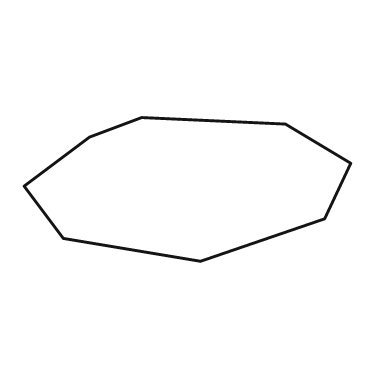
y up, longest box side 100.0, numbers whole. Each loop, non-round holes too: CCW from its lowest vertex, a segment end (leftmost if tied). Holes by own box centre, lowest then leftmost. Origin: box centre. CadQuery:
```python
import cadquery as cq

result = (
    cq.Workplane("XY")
    .moveTo(4.0, -22.0)
    .lineTo(42.0, -9.0)
    .lineTo(50.0, 8.0)
    .lineTo(30.0, 20.0)
    .lineTo(-14.0, 22.0)
    .lineTo(-30.0, 16.0)
    .lineTo(-50.0, 1.0)
    .lineTo(-38.0, -15.0)
    .close()
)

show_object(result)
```